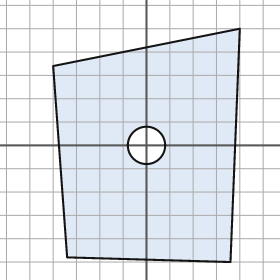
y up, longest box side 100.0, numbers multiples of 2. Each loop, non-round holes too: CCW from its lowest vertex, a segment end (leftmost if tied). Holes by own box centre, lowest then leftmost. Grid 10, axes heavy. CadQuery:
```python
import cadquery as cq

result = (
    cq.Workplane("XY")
    .moveTo(36.0, -50.0)
    .lineTo(40.0, 50.0)
    .lineTo(-40.0, 34.0)
    .lineTo(-34.0, -48.0)
    .close()
    .moveTo(0.0, 0.0)
    .circle(8.0)
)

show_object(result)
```